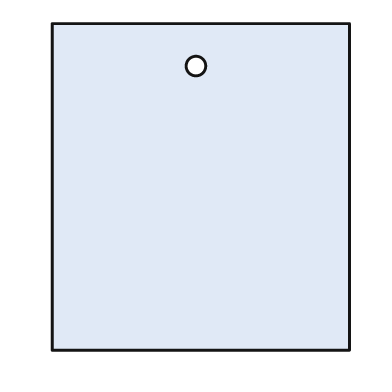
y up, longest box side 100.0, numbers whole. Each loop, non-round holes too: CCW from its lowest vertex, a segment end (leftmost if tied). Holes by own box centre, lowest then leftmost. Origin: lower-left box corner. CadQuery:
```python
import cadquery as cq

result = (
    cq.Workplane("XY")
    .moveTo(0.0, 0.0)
    .lineTo(91.0, 0.0)
    .lineTo(91.0, 100.0)
    .lineTo(0.0, 100.0)
    .close()
    .moveTo(44.0, 87.0)
    .circle(3.0)
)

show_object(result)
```